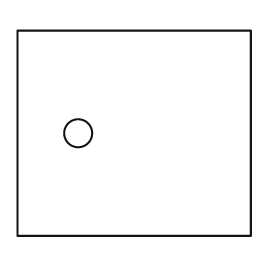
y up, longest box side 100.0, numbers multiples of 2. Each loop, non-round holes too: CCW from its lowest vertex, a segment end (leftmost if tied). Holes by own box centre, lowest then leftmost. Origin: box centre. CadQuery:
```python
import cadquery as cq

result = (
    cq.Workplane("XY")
    .moveTo(-50.0, -44.0)
    .lineTo(50.0, -44.0)
    .lineTo(50.0, 44.0)
    .lineTo(-50.0, 44.0)
    .close()
    .moveTo(-24.0, 0.0)
    .circle(6.0)
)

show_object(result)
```